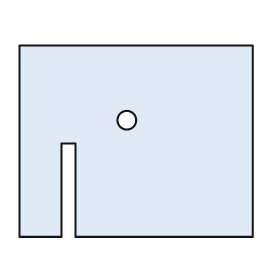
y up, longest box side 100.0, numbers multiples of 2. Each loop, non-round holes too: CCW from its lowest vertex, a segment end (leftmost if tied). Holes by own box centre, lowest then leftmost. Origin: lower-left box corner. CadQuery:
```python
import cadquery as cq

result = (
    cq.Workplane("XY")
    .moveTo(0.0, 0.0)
    .lineTo(18.0, 0.0)
    .lineTo(18.0, 40.0)
    .lineTo(24.0, 40.0)
    .lineTo(24.0, 0.0)
    .lineTo(100.0, 0.0)
    .lineTo(100.0, 82.0)
    .lineTo(0.0, 82.0)
    .close()
    .moveTo(46.0, 50.0)
    .circle(4.0)
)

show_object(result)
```